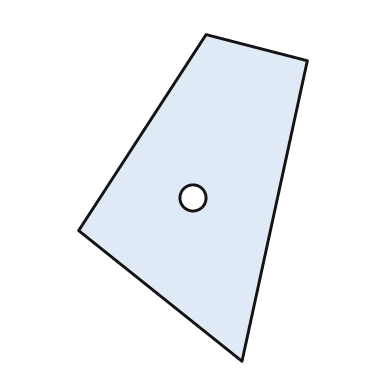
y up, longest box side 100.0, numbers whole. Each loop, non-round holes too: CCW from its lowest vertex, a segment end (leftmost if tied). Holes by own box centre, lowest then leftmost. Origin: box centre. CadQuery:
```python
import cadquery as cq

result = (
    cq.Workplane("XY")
    .moveTo(15.0, -50.0)
    .lineTo(35.0, 42.0)
    .lineTo(4.0, 50.0)
    .lineTo(-35.0, -10.0)
    .close()
    .moveTo(0.0, 0.0)
    .circle(4.0)
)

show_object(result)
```